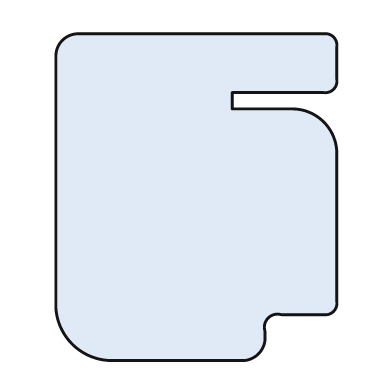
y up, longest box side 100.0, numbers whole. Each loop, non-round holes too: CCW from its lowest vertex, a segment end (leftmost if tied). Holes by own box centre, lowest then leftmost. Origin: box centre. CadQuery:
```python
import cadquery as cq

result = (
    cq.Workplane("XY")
    .moveTo(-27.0, -50.0)
    .lineTo(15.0, -50.0)
    .threePointArc((19.0, -48.0), (21.0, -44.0))
    .lineTo(21.0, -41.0)
    .threePointArc((22.0, -37.0), (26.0, -36.0))
    .lineTo(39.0, -36.0)
    .threePointArc((42.0, -35.0), (43.0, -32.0))
    .lineTo(43.0, 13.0)
    .threePointArc((39.0, 23.0), (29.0, 27.0))
    .lineTo(11.0, 27.0)
    .lineTo(11.0, 32.0)
    .lineTo(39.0, 32.0)
    .threePointArc((42.0, 33.0), (43.0, 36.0))
    .lineTo(43.0, 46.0)
    .threePointArc((42.0, 49.0), (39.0, 50.0))
    .lineTo(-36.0, 50.0)
    .threePointArc((-41.0, 48.0), (-43.0, 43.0))
    .lineTo(-43.0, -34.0)
    .threePointArc((-38.0, -45.0), (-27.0, -50.0))
    .close()
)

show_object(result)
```